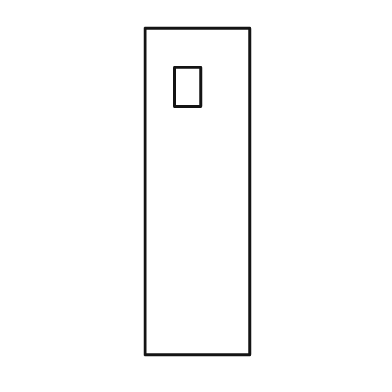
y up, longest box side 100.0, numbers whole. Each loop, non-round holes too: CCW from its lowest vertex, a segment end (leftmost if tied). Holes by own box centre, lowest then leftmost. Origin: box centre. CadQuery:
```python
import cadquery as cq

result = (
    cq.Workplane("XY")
    .moveTo(-16.0, -50.0)
    .lineTo(16.0, -50.0)
    .lineTo(16.0, 50.0)
    .lineTo(-16.0, 50.0)
    .close()
    .moveTo(-7.0, 26.0)
    .lineTo(1.0, 26.0)
    .lineTo(1.0, 38.0)
    .lineTo(-7.0, 38.0)
    .close()
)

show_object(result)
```